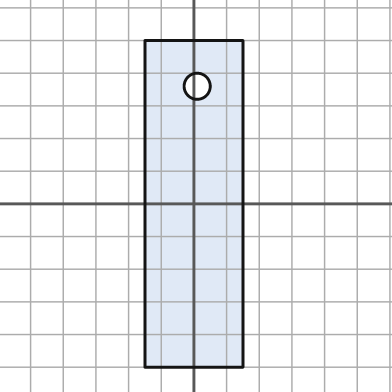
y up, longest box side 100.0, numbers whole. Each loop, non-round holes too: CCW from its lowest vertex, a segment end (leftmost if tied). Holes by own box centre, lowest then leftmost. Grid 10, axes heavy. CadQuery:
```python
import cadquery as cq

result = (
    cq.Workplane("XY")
    .moveTo(-15.0, -50.0)
    .lineTo(15.0, -50.0)
    .lineTo(15.0, 50.0)
    .lineTo(-15.0, 50.0)
    .close()
    .moveTo(1.0, 36.0)
    .circle(4.0)
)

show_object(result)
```